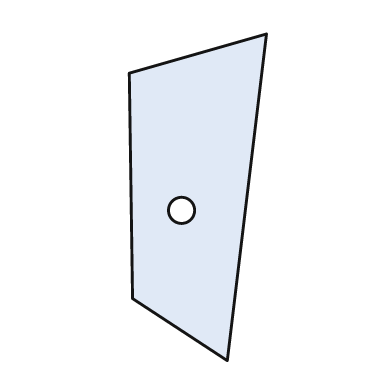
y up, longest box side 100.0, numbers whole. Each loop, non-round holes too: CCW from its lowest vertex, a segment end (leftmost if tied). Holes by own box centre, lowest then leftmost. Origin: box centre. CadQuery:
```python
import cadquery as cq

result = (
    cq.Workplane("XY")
    .moveTo(9.0, -50.0)
    .lineTo(21.0, 50.0)
    .lineTo(-21.0, 38.0)
    .lineTo(-20.0, -31.0)
    .close()
    .moveTo(-5.0, -4.0)
    .circle(4.0)
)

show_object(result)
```